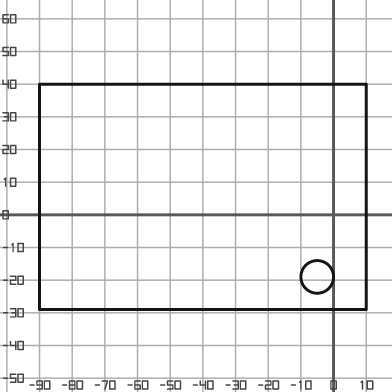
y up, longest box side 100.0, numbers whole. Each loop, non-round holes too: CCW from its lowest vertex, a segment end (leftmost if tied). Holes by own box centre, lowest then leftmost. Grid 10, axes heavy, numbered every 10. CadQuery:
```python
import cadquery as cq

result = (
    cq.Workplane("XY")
    .moveTo(-90.0, -29.0)
    .lineTo(10.0, -29.0)
    .lineTo(10.0, 40.0)
    .lineTo(-90.0, 40.0)
    .close()
    .moveTo(-5.0, -19.0)
    .circle(5.0)
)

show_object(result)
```